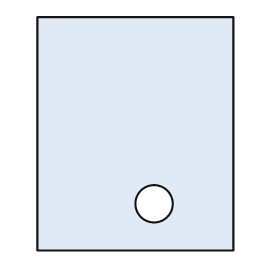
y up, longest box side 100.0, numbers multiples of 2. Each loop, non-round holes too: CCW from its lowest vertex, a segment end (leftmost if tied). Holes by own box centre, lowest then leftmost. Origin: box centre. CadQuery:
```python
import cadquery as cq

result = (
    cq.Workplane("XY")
    .moveTo(-42.0, -50.0)
    .lineTo(42.0, -50.0)
    .lineTo(42.0, 50.0)
    .lineTo(-42.0, 50.0)
    .close()
    .moveTo(8.0, -30.0)
    .circle(8.0)
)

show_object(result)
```